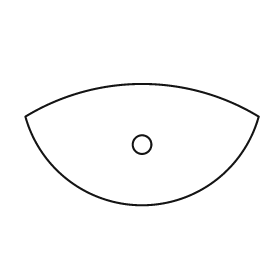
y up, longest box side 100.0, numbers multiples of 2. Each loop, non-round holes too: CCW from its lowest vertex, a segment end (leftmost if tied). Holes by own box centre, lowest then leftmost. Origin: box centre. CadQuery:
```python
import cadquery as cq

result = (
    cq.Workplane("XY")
    .moveTo(-50.0, 12.0)
    .threePointArc((0.0, -26.0), (50.0, 12.0))
    .threePointArc((0.0, 26.0), (-50.0, 12.0))
    .close()
    .moveTo(0.0, 0.0)
    .circle(4.0)
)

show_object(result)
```